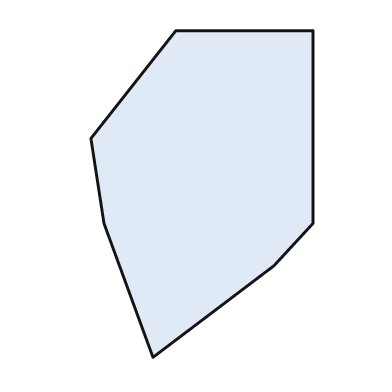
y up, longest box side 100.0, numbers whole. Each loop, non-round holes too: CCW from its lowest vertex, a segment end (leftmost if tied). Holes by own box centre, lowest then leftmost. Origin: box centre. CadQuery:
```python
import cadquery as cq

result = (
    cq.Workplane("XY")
    .moveTo(-15.0, -50.0)
    .lineTo(22.0, -22.0)
    .lineTo(34.0, -9.0)
    .lineTo(34.0, 50.0)
    .lineTo(-8.0, 50.0)
    .lineTo(-34.0, 17.0)
    .lineTo(-30.0, -9.0)
    .close()
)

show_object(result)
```